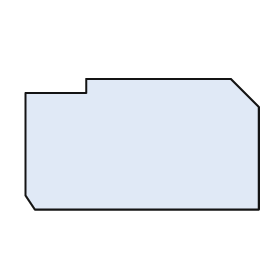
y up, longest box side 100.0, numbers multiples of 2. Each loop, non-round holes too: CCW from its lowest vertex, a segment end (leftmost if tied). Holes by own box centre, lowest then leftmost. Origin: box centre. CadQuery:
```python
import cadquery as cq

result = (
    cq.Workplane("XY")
    .moveTo(-46.0, -28.0)
    .lineTo(50.0, -28.0)
    .lineTo(50.0, 16.0)
    .lineTo(38.0, 28.0)
    .lineTo(-24.0, 28.0)
    .lineTo(-24.0, 22.0)
    .lineTo(-50.0, 22.0)
    .lineTo(-50.0, -22.0)
    .close()
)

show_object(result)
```